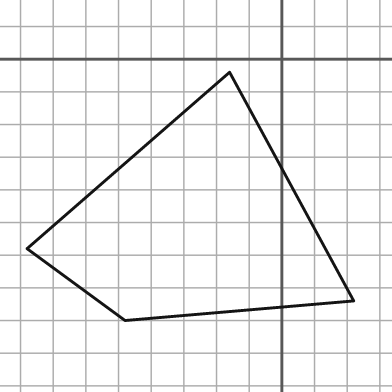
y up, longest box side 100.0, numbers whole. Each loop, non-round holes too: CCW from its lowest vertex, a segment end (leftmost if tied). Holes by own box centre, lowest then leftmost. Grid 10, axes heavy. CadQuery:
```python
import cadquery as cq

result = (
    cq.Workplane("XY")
    .moveTo(-48.0, -80.0)
    .lineTo(22.0, -74.0)
    .lineTo(-16.0, -4.0)
    .lineTo(-78.0, -58.0)
    .close()
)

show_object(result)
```